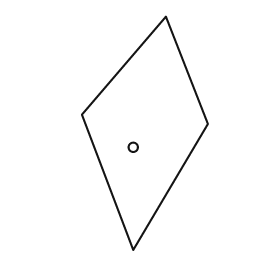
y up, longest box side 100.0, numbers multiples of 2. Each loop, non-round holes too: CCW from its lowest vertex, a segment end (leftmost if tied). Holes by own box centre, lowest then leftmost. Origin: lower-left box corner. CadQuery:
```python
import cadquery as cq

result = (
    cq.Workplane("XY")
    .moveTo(22.0, 0.0)
    .lineTo(54.0, 54.0)
    .lineTo(36.0, 100.0)
    .lineTo(0.0, 58.0)
    .close()
    .moveTo(22.0, 44.0)
    .circle(2.0)
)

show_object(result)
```